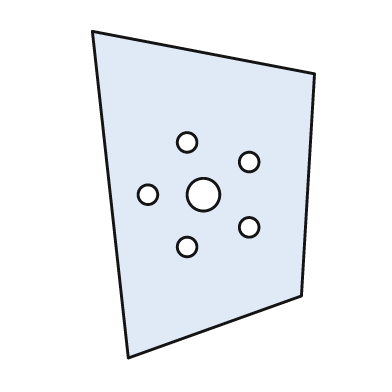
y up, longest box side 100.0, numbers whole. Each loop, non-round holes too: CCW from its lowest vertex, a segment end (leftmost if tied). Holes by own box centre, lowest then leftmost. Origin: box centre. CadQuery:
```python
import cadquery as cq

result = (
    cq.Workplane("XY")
    .moveTo(-23.0, -50.0)
    .lineTo(30.0, -31.0)
    .lineTo(34.0, 37.0)
    .lineTo(-34.0, 50.0)
    .close()
    .moveTo(-5.0, -16.0)
    .circle(3.0)
    .moveTo(14.0, -10.0)
    .circle(3.0)
    .moveTo(-17.0, 0.0)
    .circle(3.0)
    .moveTo(0.0, 0.0)
    .circle(5.0)
    .moveTo(14.0, 10.0)
    .circle(3.0)
    .moveTo(-5.0, 16.0)
    .circle(3.0)
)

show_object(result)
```